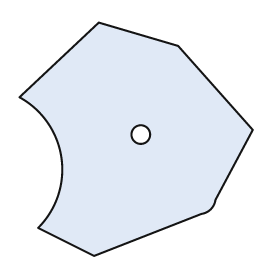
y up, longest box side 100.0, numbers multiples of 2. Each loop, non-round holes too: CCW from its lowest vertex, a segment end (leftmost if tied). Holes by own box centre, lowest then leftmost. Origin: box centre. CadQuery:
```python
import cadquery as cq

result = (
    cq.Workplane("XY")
    .moveTo(-18.0, -50.0)
    .lineTo(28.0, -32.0)
    .threePointArc((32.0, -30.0), (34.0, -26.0))
    .lineTo(50.0, 4.0)
    .lineTo(18.0, 40.0)
    .lineTo(-16.0, 50.0)
    .lineTo(-50.0, 18.0)
    .threePointArc((-32.0, -8.0), (-42.0, -38.0))
    .close()
    .moveTo(2.0, 2.0)
    .circle(4.0)
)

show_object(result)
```